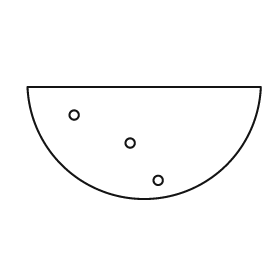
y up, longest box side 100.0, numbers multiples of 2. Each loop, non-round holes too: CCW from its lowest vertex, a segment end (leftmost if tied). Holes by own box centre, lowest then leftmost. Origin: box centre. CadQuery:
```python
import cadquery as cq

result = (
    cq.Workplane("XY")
    .moveTo(-50.0, 24.0)
    .threePointArc((0.0, -24.0), (50.0, 24.0))
    .close()
    .moveTo(6.0, -16.0)
    .circle(2.0)
    .moveTo(-6.0, 0.0)
    .circle(2.0)
    .moveTo(-30.0, 12.0)
    .circle(2.0)
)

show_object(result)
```